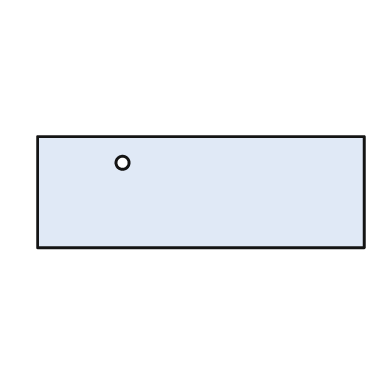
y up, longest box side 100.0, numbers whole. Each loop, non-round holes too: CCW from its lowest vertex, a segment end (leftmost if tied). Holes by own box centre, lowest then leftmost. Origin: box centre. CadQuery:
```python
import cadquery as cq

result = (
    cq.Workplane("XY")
    .moveTo(-50.0, -17.0)
    .lineTo(50.0, -17.0)
    .lineTo(50.0, 17.0)
    .lineTo(-50.0, 17.0)
    .close()
    .moveTo(-24.0, 9.0)
    .circle(2.0)
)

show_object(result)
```